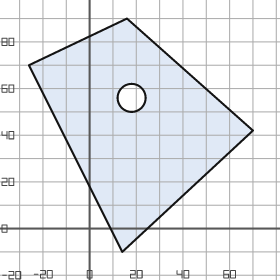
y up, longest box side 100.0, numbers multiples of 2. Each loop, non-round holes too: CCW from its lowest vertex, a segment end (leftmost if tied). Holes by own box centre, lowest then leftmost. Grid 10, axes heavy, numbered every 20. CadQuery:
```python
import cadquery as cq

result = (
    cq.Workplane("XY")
    .moveTo(14.0, -10.0)
    .lineTo(70.0, 42.0)
    .lineTo(16.0, 90.0)
    .lineTo(-26.0, 70.0)
    .close()
    .moveTo(18.0, 56.0)
    .circle(6.0)
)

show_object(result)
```